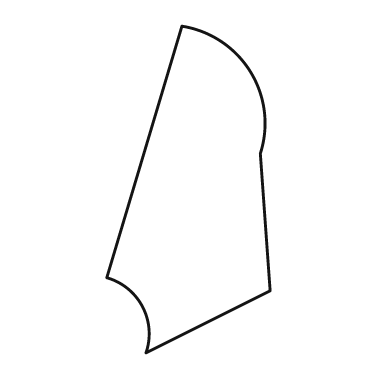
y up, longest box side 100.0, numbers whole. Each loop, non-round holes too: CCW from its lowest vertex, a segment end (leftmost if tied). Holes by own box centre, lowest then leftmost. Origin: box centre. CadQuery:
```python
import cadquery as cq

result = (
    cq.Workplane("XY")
    .moveTo(-13.0, -50.0)
    .lineTo(25.0, -31.0)
    .lineTo(22.0, 11.0)
    .threePointArc((19.0, 36.0), (-2.0, 50.0))
    .lineTo(-25.0, -27.0)
    .threePointArc((-14.0, -36.0), (-13.0, -50.0))
    .close()
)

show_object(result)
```